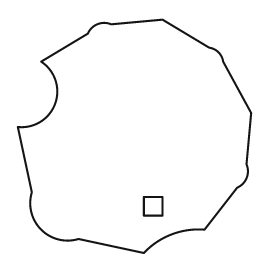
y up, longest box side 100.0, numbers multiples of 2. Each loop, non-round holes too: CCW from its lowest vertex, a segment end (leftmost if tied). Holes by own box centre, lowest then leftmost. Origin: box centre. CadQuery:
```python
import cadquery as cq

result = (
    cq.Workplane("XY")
    .moveTo(4.0, -50.0)
    .threePointArc((16.0, -42.0), (30.0, -40.0))
    .lineTo(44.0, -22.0)
    .threePointArc((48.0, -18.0), (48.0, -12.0))
    .lineTo(50.0, 10.0)
    .lineTo(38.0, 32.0)
    .threePointArc((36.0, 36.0), (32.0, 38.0))
    .lineTo(12.0, 50.0)
    .lineTo(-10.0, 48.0)
    .threePointArc((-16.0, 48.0), (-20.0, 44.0))
    .lineTo(-40.0, 32.0)
    .threePointArc((-34.0, 14.0), (-50.0, 4.0))
    .lineTo(-44.0, -24.0)
    .threePointArc((-40.0, -40.0), (-24.0, -44.0))
    .close()
    .moveTo(4.0, -34.0)
    .lineTo(12.0, -34.0)
    .lineTo(12.0, -26.0)
    .lineTo(4.0, -26.0)
    .close()
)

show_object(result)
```